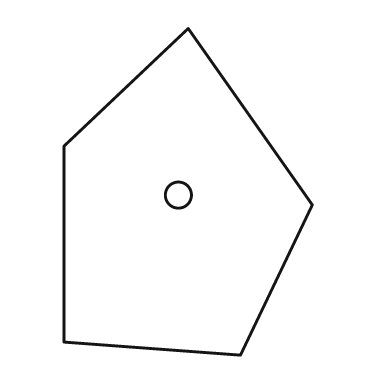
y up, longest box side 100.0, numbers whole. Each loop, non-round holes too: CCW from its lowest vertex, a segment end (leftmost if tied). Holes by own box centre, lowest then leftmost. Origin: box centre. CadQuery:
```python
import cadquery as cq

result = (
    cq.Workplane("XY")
    .moveTo(16.0, -50.0)
    .lineTo(38.0, -4.0)
    .lineTo(0.0, 50.0)
    .lineTo(-38.0, 14.0)
    .lineTo(-38.0, -46.0)
    .close()
    .moveTo(-3.0, -1.0)
    .circle(4.0)
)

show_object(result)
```